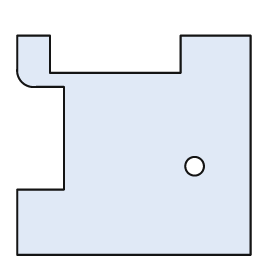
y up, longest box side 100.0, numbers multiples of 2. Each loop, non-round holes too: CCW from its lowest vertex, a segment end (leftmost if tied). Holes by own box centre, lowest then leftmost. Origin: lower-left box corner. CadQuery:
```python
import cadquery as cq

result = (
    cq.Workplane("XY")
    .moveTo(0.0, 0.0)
    .lineTo(100.0, 0.0)
    .lineTo(100.0, 94.0)
    .lineTo(70.0, 94.0)
    .lineTo(70.0, 78.0)
    .lineTo(14.0, 78.0)
    .lineTo(14.0, 94.0)
    .lineTo(0.0, 94.0)
    .lineTo(0.0, 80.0)
    .threePointArc((2.0, 74.0), (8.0, 72.0))
    .lineTo(20.0, 72.0)
    .lineTo(20.0, 28.0)
    .lineTo(0.0, 28.0)
    .close()
    .moveTo(76.0, 38.0)
    .circle(4.0)
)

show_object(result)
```